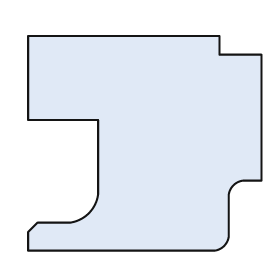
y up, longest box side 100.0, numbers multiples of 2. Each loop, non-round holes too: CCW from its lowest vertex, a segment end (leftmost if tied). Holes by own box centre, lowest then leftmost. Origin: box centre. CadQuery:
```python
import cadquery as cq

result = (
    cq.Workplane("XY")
    .moveTo(-50.0, -46.0)
    .lineTo(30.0, -46.0)
    .threePointArc((34.0, -44.0), (36.0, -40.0))
    .lineTo(36.0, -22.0)
    .threePointArc((38.0, -18.0), (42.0, -16.0))
    .lineTo(50.0, -16.0)
    .lineTo(50.0, 38.0)
    .lineTo(32.0, 38.0)
    .lineTo(32.0, 46.0)
    .lineTo(-50.0, 46.0)
    .lineTo(-50.0, 10.0)
    .lineTo(-20.0, 10.0)
    .lineTo(-20.0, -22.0)
    .threePointArc((-24.0, -30.0), (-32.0, -34.0))
    .lineTo(-46.0, -34.0)
    .lineTo(-50.0, -38.0)
    .close()
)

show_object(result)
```